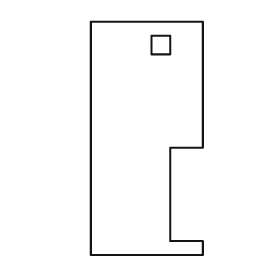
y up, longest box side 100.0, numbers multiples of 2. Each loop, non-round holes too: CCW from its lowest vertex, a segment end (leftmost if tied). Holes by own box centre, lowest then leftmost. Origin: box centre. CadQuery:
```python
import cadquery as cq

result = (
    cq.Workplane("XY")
    .moveTo(-24.0, -50.0)
    .lineTo(24.0, -50.0)
    .lineTo(24.0, -44.0)
    .lineTo(10.0, -44.0)
    .lineTo(10.0, -4.0)
    .lineTo(24.0, -4.0)
    .lineTo(24.0, 50.0)
    .lineTo(-24.0, 50.0)
    .close()
    .moveTo(2.0, 36.0)
    .lineTo(10.0, 36.0)
    .lineTo(10.0, 44.0)
    .lineTo(2.0, 44.0)
    .close()
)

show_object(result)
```